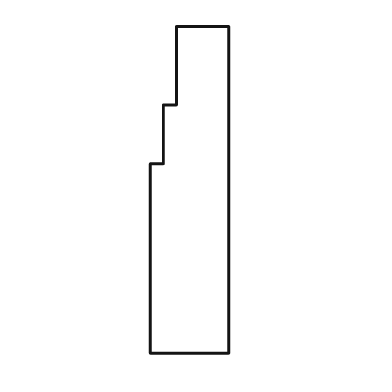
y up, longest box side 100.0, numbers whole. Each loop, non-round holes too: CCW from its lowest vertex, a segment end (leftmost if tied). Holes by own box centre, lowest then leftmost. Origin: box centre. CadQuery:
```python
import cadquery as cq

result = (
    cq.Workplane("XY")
    .moveTo(-12.0, -50.0)
    .lineTo(12.0, -50.0)
    .lineTo(12.0, 50.0)
    .lineTo(-4.0, 50.0)
    .lineTo(-4.0, 26.0)
    .lineTo(-8.0, 26.0)
    .lineTo(-8.0, 8.0)
    .lineTo(-12.0, 8.0)
    .close()
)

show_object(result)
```